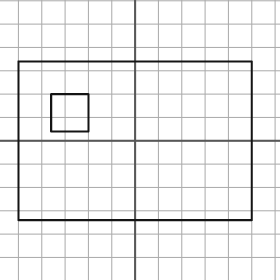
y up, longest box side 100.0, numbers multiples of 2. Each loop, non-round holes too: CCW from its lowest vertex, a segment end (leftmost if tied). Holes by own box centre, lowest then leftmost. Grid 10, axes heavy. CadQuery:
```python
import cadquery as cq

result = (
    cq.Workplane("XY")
    .moveTo(-50.0, -34.0)
    .lineTo(50.0, -34.0)
    .lineTo(50.0, 34.0)
    .lineTo(-50.0, 34.0)
    .close()
    .moveTo(-36.0, 4.0)
    .lineTo(-20.0, 4.0)
    .lineTo(-20.0, 20.0)
    .lineTo(-36.0, 20.0)
    .close()
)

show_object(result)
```